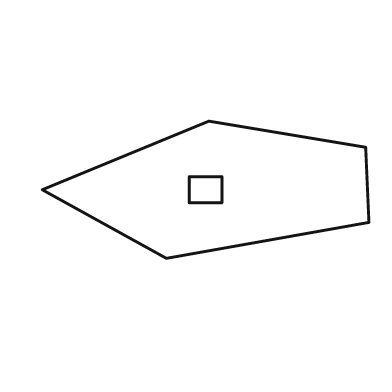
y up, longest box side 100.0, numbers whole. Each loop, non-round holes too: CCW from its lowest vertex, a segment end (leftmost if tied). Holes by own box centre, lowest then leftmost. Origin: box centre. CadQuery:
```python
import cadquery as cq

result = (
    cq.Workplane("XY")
    .moveTo(-12.0, -21.0)
    .lineTo(50.0, -10.0)
    .lineTo(49.0, 13.0)
    .lineTo(1.0, 21.0)
    .lineTo(-50.0, 0.0)
    .close()
    .moveTo(-5.0, -4.0)
    .lineTo(5.0, -4.0)
    .lineTo(5.0, 4.0)
    .lineTo(-5.0, 4.0)
    .close()
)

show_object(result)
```